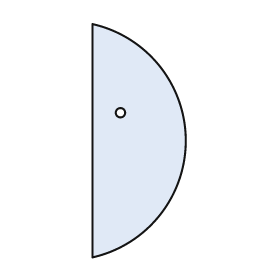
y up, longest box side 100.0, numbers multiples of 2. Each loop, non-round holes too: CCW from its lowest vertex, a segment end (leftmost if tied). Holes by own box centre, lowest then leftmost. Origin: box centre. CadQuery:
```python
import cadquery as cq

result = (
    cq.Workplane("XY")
    .moveTo(-20.0, -50.0)
    .threePointArc((20.0, 0.0), (-20.0, 50.0))
    .close()
    .moveTo(-8.0, 12.0)
    .circle(2.0)
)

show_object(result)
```